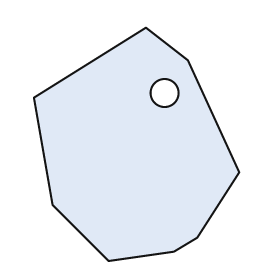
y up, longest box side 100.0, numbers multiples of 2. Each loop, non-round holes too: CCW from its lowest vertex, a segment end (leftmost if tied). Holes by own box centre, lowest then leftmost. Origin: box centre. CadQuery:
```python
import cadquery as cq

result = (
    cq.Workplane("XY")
    .moveTo(-12.0, -50.0)
    .lineTo(16.0, -46.0)
    .lineTo(26.0, -40.0)
    .lineTo(44.0, -12.0)
    .lineTo(22.0, 36.0)
    .lineTo(4.0, 50.0)
    .lineTo(-44.0, 20.0)
    .lineTo(-36.0, -26.0)
    .close()
    .moveTo(12.0, 22.0)
    .circle(6.0)
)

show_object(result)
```